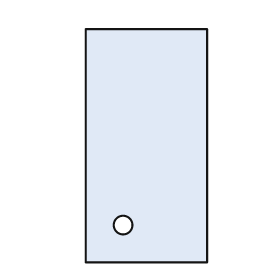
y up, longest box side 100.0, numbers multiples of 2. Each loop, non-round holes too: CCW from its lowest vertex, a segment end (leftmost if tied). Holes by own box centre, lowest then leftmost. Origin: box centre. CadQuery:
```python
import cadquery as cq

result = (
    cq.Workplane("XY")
    .moveTo(-26.0, -50.0)
    .lineTo(26.0, -50.0)
    .lineTo(26.0, 50.0)
    .lineTo(-26.0, 50.0)
    .close()
    .moveTo(-10.0, -34.0)
    .circle(4.0)
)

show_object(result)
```